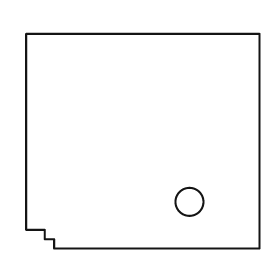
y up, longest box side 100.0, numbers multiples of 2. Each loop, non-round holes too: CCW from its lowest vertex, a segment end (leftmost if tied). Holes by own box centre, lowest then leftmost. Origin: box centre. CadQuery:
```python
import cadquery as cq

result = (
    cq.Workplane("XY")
    .moveTo(-38.0, -46.0)
    .lineTo(50.0, -46.0)
    .lineTo(50.0, 46.0)
    .lineTo(-50.0, 46.0)
    .lineTo(-50.0, -38.0)
    .lineTo(-42.0, -38.0)
    .lineTo(-42.0, -42.0)
    .lineTo(-38.0, -42.0)
    .close()
    .moveTo(20.0, -26.0)
    .circle(6.0)
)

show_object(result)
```